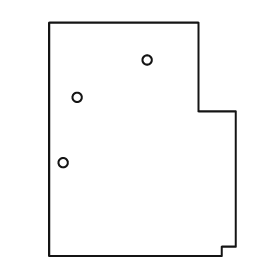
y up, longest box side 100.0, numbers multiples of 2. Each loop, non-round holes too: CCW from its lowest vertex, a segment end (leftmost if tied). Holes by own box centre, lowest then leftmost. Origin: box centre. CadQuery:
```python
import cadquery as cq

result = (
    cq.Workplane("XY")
    .moveTo(-40.0, -50.0)
    .lineTo(34.0, -50.0)
    .lineTo(34.0, -46.0)
    .lineTo(40.0, -46.0)
    .lineTo(40.0, 12.0)
    .lineTo(24.0, 12.0)
    .lineTo(24.0, 50.0)
    .lineTo(-40.0, 50.0)
    .close()
    .moveTo(-34.0, -10.0)
    .circle(2.0)
    .moveTo(-28.0, 18.0)
    .circle(2.0)
    .moveTo(2.0, 34.0)
    .circle(2.0)
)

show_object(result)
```